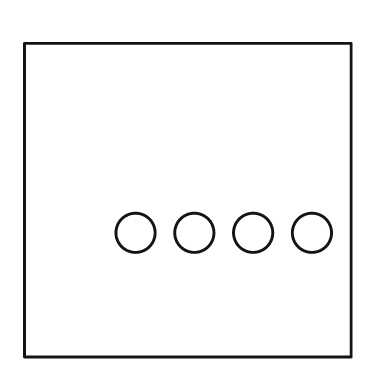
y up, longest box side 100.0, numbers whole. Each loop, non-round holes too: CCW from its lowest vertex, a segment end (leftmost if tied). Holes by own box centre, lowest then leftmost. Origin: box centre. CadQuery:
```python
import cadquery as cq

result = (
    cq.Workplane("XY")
    .moveTo(-50.0, -48.0)
    .lineTo(50.0, -48.0)
    .lineTo(50.0, 48.0)
    .lineTo(-50.0, 48.0)
    .close()
    .moveTo(-16.0, -10.0)
    .circle(6.0)
    .moveTo(2.0, -10.0)
    .circle(6.0)
    .moveTo(20.0, -10.0)
    .circle(6.0)
    .moveTo(38.0, -10.0)
    .circle(6.0)
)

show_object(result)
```